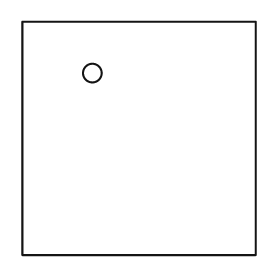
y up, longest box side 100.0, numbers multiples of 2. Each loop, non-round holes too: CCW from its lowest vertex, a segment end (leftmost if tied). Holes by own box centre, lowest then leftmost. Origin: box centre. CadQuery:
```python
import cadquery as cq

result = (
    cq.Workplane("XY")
    .moveTo(-50.0, -50.0)
    .lineTo(50.0, -50.0)
    .lineTo(50.0, 50.0)
    .lineTo(-50.0, 50.0)
    .close()
    .moveTo(-20.0, 28.0)
    .circle(4.0)
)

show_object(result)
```